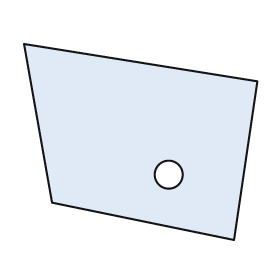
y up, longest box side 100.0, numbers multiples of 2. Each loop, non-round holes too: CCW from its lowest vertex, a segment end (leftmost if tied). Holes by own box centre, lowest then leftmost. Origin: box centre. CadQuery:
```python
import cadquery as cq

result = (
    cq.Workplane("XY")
    .moveTo(40.0, -42.0)
    .lineTo(50.0, 26.0)
    .lineTo(-50.0, 42.0)
    .lineTo(-38.0, -26.0)
    .close()
    .moveTo(12.0, -14.0)
    .circle(6.0)
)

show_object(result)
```